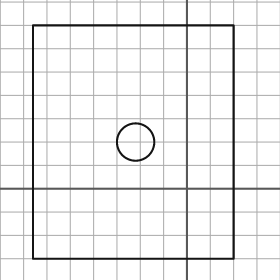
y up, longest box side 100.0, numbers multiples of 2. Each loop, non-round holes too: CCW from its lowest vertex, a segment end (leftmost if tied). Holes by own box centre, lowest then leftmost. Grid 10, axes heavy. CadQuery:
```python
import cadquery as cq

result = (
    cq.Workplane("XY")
    .moveTo(-66.0, -30.0)
    .lineTo(20.0, -30.0)
    .lineTo(20.0, 70.0)
    .lineTo(-66.0, 70.0)
    .close()
    .moveTo(-22.0, 20.0)
    .circle(8.0)
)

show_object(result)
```